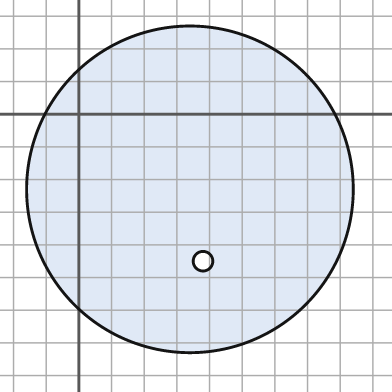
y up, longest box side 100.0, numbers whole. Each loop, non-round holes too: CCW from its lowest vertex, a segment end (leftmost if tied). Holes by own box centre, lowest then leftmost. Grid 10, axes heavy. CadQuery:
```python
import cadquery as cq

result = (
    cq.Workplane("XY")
    .moveTo(34.0, -23.0)
    .circle(50.0)
    .moveTo(38.0, -45.0)
    .circle(3.0)
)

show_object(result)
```